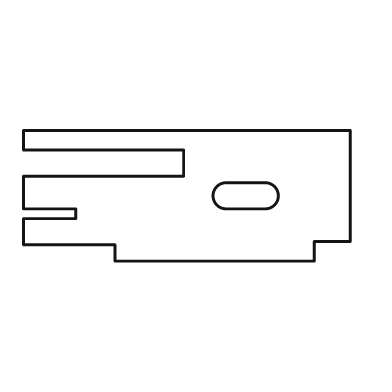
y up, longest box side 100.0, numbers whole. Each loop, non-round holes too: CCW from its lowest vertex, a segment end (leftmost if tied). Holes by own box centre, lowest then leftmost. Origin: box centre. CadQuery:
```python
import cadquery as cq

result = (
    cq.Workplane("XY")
    .moveTo(-22.0, -20.0)
    .lineTo(39.0, -20.0)
    .lineTo(39.0, -14.0)
    .lineTo(50.0, -14.0)
    .lineTo(50.0, 20.0)
    .lineTo(-50.0, 20.0)
    .lineTo(-50.0, 14.0)
    .lineTo(-1.0, 14.0)
    .lineTo(-1.0, 6.0)
    .lineTo(-50.0, 6.0)
    .lineTo(-50.0, -4.0)
    .lineTo(-34.0, -4.0)
    .lineTo(-34.0, -7.0)
    .lineTo(-50.0, -7.0)
    .lineTo(-50.0, -15.0)
    .lineTo(-22.0, -15.0)
    .close()
    .moveTo(12.0, -4.0)
    .lineTo(24.0, -4.0)
    .threePointArc((28.0, 0.0), (24.0, 4.0))
    .lineTo(12.0, 4.0)
    .threePointArc((8.0, 0.0), (12.0, -4.0))
    .close()
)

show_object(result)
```